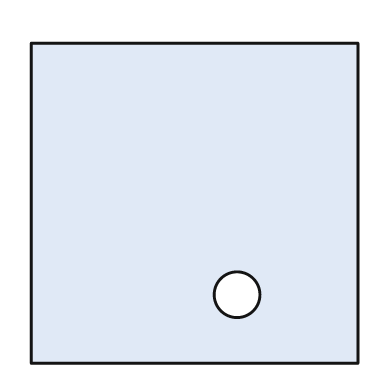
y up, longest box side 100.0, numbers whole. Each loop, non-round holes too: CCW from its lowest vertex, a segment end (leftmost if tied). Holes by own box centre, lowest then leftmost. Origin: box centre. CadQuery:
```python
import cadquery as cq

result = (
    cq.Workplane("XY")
    .moveTo(-50.0, -49.0)
    .lineTo(50.0, -49.0)
    .lineTo(50.0, 49.0)
    .lineTo(-50.0, 49.0)
    .close()
    .moveTo(13.0, -28.0)
    .circle(7.0)
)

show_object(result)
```